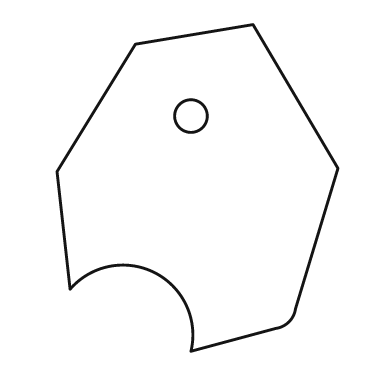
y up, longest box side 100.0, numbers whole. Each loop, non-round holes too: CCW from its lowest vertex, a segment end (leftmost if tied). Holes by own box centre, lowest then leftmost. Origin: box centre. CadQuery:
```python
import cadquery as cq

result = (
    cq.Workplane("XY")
    .moveTo(-2.0, -50.0)
    .lineTo(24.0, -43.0)
    .threePointArc((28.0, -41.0), (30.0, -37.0))
    .lineTo(43.0, 6.0)
    .lineTo(17.0, 50.0)
    .lineTo(-19.0, 44.0)
    .lineTo(-43.0, 5.0)
    .lineTo(-39.0, -31.0)
    .threePointArc((-13.0, -26.0), (-2.0, -50.0))
    .close()
    .moveTo(-2.0, 22.0)
    .circle(5.0)
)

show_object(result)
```